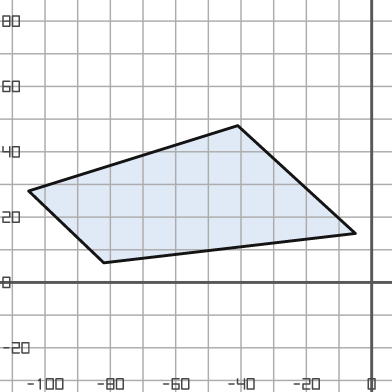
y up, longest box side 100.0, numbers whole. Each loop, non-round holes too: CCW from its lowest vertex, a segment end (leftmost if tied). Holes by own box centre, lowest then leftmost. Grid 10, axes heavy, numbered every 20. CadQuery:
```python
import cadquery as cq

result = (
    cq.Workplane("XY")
    .moveTo(-82.0, 6.0)
    .lineTo(-5.0, 15.0)
    .lineTo(-41.0, 48.0)
    .lineTo(-105.0, 28.0)
    .close()
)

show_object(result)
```